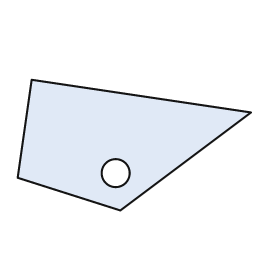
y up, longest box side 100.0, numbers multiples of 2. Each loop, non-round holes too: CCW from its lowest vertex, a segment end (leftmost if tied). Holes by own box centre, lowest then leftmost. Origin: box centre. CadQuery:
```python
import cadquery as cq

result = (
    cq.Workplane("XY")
    .moveTo(-6.0, -28.0)
    .lineTo(50.0, 14.0)
    .lineTo(-44.0, 28.0)
    .lineTo(-50.0, -14.0)
    .close()
    .moveTo(-8.0, -12.0)
    .circle(6.0)
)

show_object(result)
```